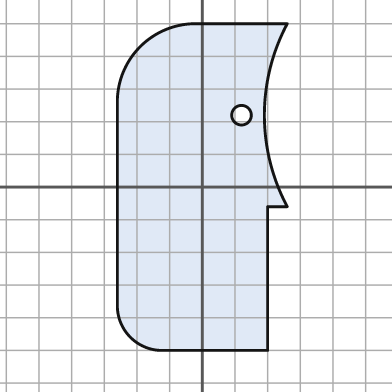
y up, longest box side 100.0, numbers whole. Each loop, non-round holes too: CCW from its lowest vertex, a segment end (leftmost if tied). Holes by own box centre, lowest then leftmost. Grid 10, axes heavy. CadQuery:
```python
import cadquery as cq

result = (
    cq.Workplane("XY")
    .moveTo(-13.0, -50.0)
    .lineTo(20.0, -50.0)
    .lineTo(20.0, -6.0)
    .lineTo(26.0, -6.0)
    .threePointArc((19.0, 22.0), (26.0, 50.0))
    .lineTo(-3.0, 50.0)
    .threePointArc((-19.0, 43.0), (-26.0, 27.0))
    .lineTo(-26.0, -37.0)
    .threePointArc((-22.0, -46.0), (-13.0, -50.0))
    .close()
    .moveTo(12.0, 22.0)
    .circle(3.0)
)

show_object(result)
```